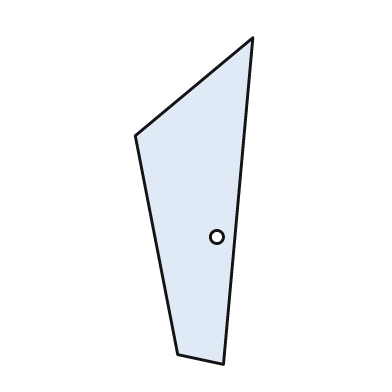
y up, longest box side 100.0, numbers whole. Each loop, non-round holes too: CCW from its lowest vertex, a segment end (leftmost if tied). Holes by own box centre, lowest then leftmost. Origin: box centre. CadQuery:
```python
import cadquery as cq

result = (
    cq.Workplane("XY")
    .moveTo(9.0, -50.0)
    .lineTo(18.0, 50.0)
    .lineTo(-18.0, 20.0)
    .lineTo(-5.0, -47.0)
    .close()
    .moveTo(7.0, -11.0)
    .circle(2.0)
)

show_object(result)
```